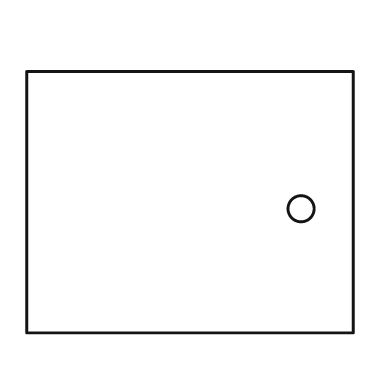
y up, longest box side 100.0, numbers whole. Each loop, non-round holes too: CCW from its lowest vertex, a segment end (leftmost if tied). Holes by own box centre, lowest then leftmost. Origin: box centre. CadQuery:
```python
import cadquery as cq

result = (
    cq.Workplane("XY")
    .moveTo(-50.0, -40.0)
    .lineTo(50.0, -40.0)
    .lineTo(50.0, 40.0)
    .lineTo(-50.0, 40.0)
    .close()
    .moveTo(34.0, -2.0)
    .circle(4.0)
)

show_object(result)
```